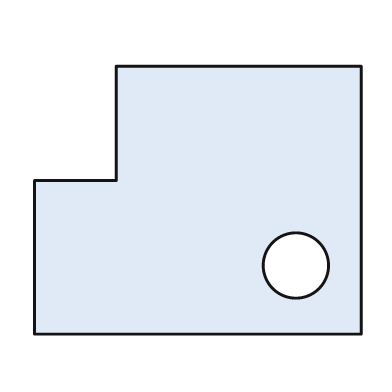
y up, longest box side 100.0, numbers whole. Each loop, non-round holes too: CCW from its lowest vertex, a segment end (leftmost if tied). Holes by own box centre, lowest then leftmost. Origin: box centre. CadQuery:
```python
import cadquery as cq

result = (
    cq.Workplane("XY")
    .moveTo(-50.0, -41.0)
    .lineTo(50.0, -41.0)
    .lineTo(50.0, 41.0)
    .lineTo(-25.0, 41.0)
    .lineTo(-25.0, 6.0)
    .lineTo(-50.0, 6.0)
    .close()
    .moveTo(30.0, -20.0)
    .circle(10.0)
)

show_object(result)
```